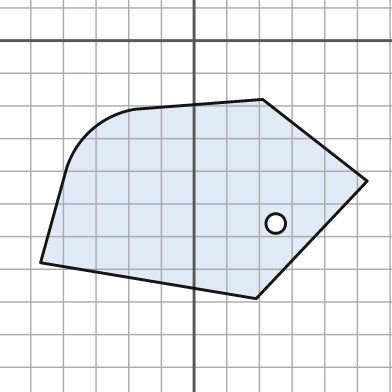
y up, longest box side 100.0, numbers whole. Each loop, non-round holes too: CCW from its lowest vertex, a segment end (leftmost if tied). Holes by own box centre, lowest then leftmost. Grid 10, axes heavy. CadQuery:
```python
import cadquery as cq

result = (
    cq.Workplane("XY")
    .moveTo(19.0, -79.0)
    .lineTo(53.0, -43.0)
    .lineTo(21.0, -18.0)
    .lineTo(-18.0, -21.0)
    .threePointArc((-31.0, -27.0), (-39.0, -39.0))
    .lineTo(-47.0, -68.0)
    .close()
    .moveTo(25.0, -56.0)
    .circle(3.0)
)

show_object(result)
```